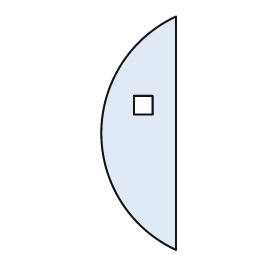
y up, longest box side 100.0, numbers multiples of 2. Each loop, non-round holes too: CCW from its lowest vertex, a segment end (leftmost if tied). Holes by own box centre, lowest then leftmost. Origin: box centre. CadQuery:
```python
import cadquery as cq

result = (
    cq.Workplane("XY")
    .moveTo(16.0, -50.0)
    .lineTo(16.0, 50.0)
    .threePointArc((-16.0, 0.0), (16.0, -50.0))
    .close()
    .moveTo(-2.0, 8.0)
    .lineTo(6.0, 8.0)
    .lineTo(6.0, 16.0)
    .lineTo(-2.0, 16.0)
    .close()
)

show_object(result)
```